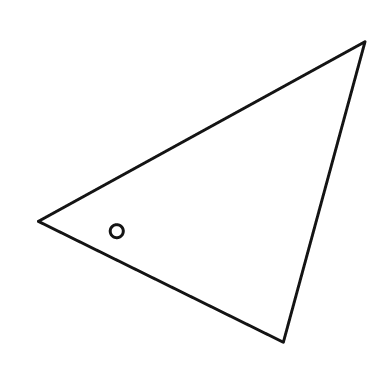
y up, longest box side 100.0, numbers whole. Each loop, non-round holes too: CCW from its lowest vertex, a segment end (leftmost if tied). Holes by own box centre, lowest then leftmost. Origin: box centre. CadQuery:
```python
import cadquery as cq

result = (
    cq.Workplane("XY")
    .moveTo(25.0, -46.0)
    .lineTo(50.0, 46.0)
    .lineTo(-50.0, -9.0)
    .close()
    .moveTo(-26.0, -12.0)
    .circle(2.0)
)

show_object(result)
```